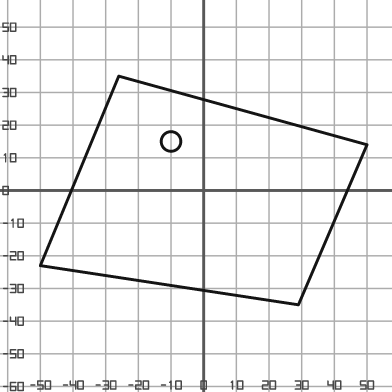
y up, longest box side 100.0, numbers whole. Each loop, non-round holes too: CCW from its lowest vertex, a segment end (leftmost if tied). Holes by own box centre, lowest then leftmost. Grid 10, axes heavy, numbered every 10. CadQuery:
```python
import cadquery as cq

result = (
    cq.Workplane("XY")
    .moveTo(29.0, -35.0)
    .lineTo(50.0, 14.0)
    .lineTo(-26.0, 35.0)
    .lineTo(-50.0, -23.0)
    .close()
    .moveTo(-10.0, 15.0)
    .circle(3.0)
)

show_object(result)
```